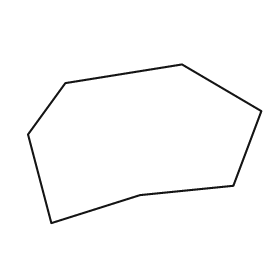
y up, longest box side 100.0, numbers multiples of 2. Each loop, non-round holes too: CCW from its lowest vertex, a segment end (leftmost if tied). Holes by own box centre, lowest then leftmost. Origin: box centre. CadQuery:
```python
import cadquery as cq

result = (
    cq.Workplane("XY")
    .moveTo(-40.0, -34.0)
    .lineTo(-2.0, -22.0)
    .lineTo(38.0, -18.0)
    .lineTo(50.0, 14.0)
    .lineTo(16.0, 34.0)
    .lineTo(-34.0, 26.0)
    .lineTo(-50.0, 4.0)
    .close()
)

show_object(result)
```